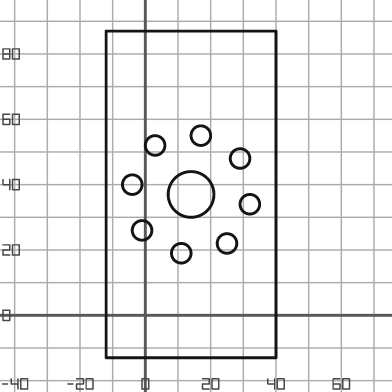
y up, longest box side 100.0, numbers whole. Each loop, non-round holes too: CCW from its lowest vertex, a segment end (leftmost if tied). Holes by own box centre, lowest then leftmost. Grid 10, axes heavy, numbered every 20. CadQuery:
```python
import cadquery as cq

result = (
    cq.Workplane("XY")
    .moveTo(-12.0, -13.0)
    .lineTo(40.0, -13.0)
    .lineTo(40.0, 87.0)
    .lineTo(-12.0, 87.0)
    .close()
    .moveTo(11.0, 19.0)
    .circle(3.0)
    .moveTo(25.0, 22.0)
    .circle(3.0)
    .moveTo(-1.0, 26.0)
    .circle(3.0)
    .moveTo(32.0, 34.0)
    .circle(3.0)
    .moveTo(14.0, 37.0)
    .circle(7.0)
    .moveTo(-4.0, 40.0)
    .circle(3.0)
    .moveTo(29.0, 48.0)
    .circle(3.0)
    .moveTo(3.0, 52.0)
    .circle(3.0)
    .moveTo(17.0, 55.0)
    .circle(3.0)
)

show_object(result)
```